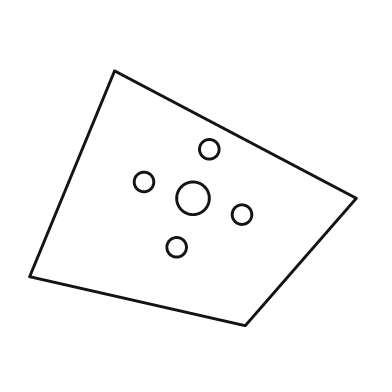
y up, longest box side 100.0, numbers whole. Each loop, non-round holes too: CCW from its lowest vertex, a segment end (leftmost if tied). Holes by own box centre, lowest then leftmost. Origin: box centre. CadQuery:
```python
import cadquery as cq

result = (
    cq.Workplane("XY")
    .moveTo(16.0, -39.0)
    .lineTo(50.0, 0.0)
    .lineTo(-24.0, 39.0)
    .lineTo(-50.0, -24.0)
    .close()
    .moveTo(-5.0, -15.0)
    .circle(3.0)
    .moveTo(15.0, -5.0)
    .circle(3.0)
    .moveTo(0.0, 0.0)
    .circle(5.0)
    .moveTo(-15.0, 5.0)
    .circle(3.0)
    .moveTo(5.0, 15.0)
    .circle(3.0)
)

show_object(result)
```